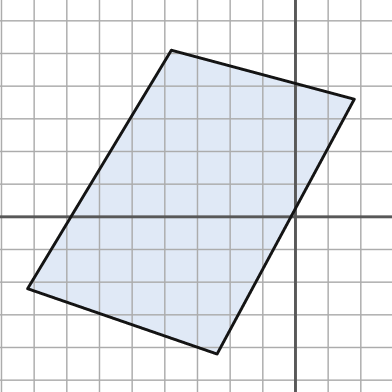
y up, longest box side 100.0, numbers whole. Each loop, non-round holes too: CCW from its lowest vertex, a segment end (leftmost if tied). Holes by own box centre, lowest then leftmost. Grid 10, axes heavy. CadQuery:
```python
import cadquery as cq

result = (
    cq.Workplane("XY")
    .moveTo(-24.0, -42.0)
    .lineTo(18.0, 36.0)
    .lineTo(-38.0, 51.0)
    .lineTo(-82.0, -22.0)
    .close()
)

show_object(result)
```